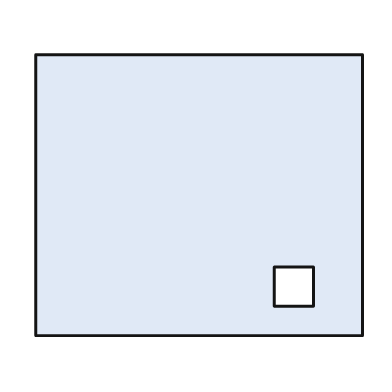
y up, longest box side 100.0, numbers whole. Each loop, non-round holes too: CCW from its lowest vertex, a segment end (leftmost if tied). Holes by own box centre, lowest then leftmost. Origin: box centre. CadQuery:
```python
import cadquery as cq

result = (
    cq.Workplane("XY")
    .moveTo(-50.0, -43.0)
    .lineTo(50.0, -43.0)
    .lineTo(50.0, 43.0)
    .lineTo(-50.0, 43.0)
    .close()
    .moveTo(23.0, -34.0)
    .lineTo(35.0, -34.0)
    .lineTo(35.0, -22.0)
    .lineTo(23.0, -22.0)
    .close()
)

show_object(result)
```